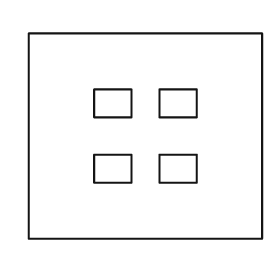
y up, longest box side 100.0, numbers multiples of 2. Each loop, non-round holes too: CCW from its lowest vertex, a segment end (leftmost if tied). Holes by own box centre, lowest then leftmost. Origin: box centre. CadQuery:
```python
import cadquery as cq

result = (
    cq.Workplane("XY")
    .moveTo(-50.0, -44.0)
    .lineTo(50.0, -44.0)
    .lineTo(50.0, 44.0)
    .lineTo(-50.0, 44.0)
    .close()
    .moveTo(-22.0, -20.0)
    .lineTo(-6.0, -20.0)
    .lineTo(-6.0, -8.0)
    .lineTo(-22.0, -8.0)
    .close()
    .moveTo(6.0, -20.0)
    .lineTo(22.0, -20.0)
    .lineTo(22.0, -8.0)
    .lineTo(6.0, -8.0)
    .close()
    .moveTo(-22.0, 8.0)
    .lineTo(-6.0, 8.0)
    .lineTo(-6.0, 20.0)
    .lineTo(-22.0, 20.0)
    .close()
    .moveTo(6.0, 8.0)
    .lineTo(22.0, 8.0)
    .lineTo(22.0, 20.0)
    .lineTo(6.0, 20.0)
    .close()
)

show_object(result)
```